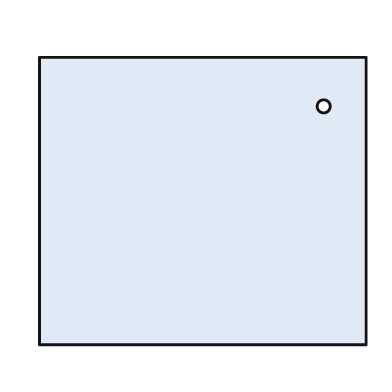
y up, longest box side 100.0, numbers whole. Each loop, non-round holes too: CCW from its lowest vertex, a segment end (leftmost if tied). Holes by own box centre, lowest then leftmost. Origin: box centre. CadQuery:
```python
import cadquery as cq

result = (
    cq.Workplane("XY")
    .moveTo(-50.0, -44.0)
    .lineTo(50.0, -44.0)
    .lineTo(50.0, 44.0)
    .lineTo(-50.0, 44.0)
    .close()
    .moveTo(37.0, 29.0)
    .circle(2.0)
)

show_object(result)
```